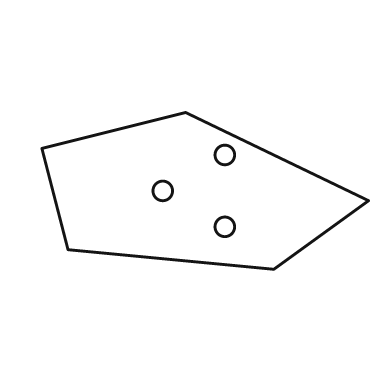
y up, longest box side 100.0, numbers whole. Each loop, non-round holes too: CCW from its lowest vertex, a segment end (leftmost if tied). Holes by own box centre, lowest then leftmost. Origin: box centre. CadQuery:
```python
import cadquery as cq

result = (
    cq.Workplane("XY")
    .moveTo(21.0, -24.0)
    .lineTo(50.0, -3.0)
    .lineTo(-6.0, 24.0)
    .lineTo(-50.0, 13.0)
    .lineTo(-42.0, -18.0)
    .close()
    .moveTo(6.0, -11.0)
    .circle(3.0)
    .moveTo(-13.0, 0.0)
    .circle(3.0)
    .moveTo(6.0, 11.0)
    .circle(3.0)
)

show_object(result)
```